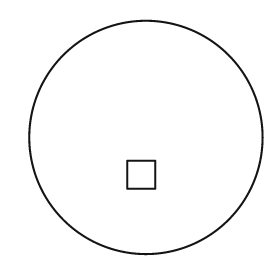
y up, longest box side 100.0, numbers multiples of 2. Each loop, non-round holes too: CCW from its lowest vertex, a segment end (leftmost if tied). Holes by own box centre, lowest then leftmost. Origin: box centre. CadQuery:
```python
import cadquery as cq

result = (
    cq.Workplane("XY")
    .moveTo(0.0, 0.0)
    .circle(50.0)
    .moveTo(-8.0, -22.0)
    .lineTo(4.0, -22.0)
    .lineTo(4.0, -10.0)
    .lineTo(-8.0, -10.0)
    .close()
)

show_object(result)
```